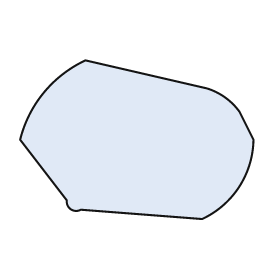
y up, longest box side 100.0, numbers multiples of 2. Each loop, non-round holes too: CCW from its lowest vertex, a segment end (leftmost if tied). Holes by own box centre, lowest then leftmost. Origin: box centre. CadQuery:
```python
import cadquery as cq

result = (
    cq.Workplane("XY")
    .moveTo(28.0, -34.0)
    .threePointArc((44.0, -20.0), (50.0, 0.0))
    .lineTo(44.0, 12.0)
    .threePointArc((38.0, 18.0), (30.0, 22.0))
    .lineTo(-22.0, 34.0)
    .threePointArc((-40.0, 20.0), (-50.0, 0.0))
    .lineTo(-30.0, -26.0)
    .threePointArc((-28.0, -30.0), (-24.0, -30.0))
    .close()
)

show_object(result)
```